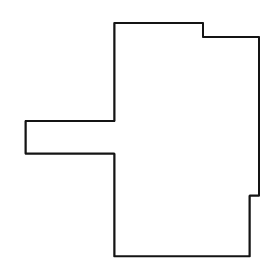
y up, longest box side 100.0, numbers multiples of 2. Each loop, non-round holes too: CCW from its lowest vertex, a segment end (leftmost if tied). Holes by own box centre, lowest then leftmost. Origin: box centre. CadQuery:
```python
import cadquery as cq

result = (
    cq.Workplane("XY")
    .moveTo(-12.0, -50.0)
    .lineTo(46.0, -50.0)
    .lineTo(46.0, -24.0)
    .lineTo(50.0, -24.0)
    .lineTo(50.0, 44.0)
    .lineTo(26.0, 44.0)
    .lineTo(26.0, 50.0)
    .lineTo(-12.0, 50.0)
    .lineTo(-12.0, 8.0)
    .lineTo(-50.0, 8.0)
    .lineTo(-50.0, -6.0)
    .lineTo(-12.0, -6.0)
    .close()
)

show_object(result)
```